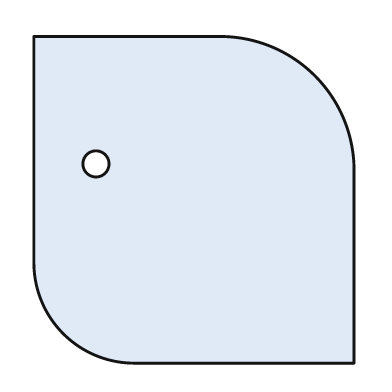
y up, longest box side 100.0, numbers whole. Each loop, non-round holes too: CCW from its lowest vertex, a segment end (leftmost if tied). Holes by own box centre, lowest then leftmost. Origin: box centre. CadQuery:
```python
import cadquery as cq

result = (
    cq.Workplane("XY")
    .moveTo(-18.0, -50.0)
    .lineTo(49.0, -50.0)
    .lineTo(49.0, 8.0)
    .threePointArc((37.0, 38.0), (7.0, 50.0))
    .lineTo(-49.0, 50.0)
    .lineTo(-49.0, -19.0)
    .threePointArc((-40.0, -41.0), (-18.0, -50.0))
    .close()
    .moveTo(-30.0, 11.0)
    .circle(4.0)
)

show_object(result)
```